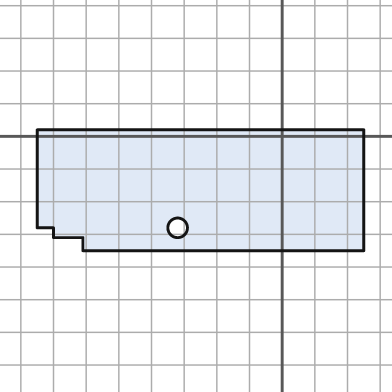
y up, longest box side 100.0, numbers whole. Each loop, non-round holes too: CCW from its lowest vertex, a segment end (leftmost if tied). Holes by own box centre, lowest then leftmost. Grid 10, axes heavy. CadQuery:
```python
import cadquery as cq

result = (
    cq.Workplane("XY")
    .moveTo(-61.0, -35.0)
    .lineTo(25.0, -35.0)
    .lineTo(25.0, 2.0)
    .lineTo(-75.0, 2.0)
    .lineTo(-75.0, -28.0)
    .lineTo(-70.0, -28.0)
    .lineTo(-70.0, -31.0)
    .lineTo(-61.0, -31.0)
    .close()
    .moveTo(-32.0, -28.0)
    .circle(3.0)
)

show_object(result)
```